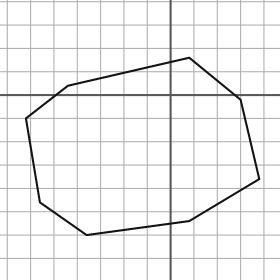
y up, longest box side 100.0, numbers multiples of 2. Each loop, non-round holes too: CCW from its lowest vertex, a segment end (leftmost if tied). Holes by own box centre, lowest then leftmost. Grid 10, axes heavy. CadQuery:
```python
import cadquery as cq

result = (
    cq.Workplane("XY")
    .moveTo(-36.0, -60.0)
    .lineTo(8.0, -54.0)
    .lineTo(38.0, -36.0)
    .lineTo(30.0, -2.0)
    .lineTo(8.0, 16.0)
    .lineTo(-44.0, 4.0)
    .lineTo(-62.0, -10.0)
    .lineTo(-56.0, -46.0)
    .close()
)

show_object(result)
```